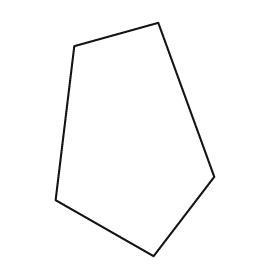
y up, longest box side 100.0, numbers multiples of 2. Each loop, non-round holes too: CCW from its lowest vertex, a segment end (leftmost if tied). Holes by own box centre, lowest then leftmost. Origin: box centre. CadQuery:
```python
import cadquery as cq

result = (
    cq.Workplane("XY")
    .moveTo(8.0, -50.0)
    .lineTo(34.0, -16.0)
    .lineTo(10.0, 50.0)
    .lineTo(-26.0, 40.0)
    .lineTo(-34.0, -26.0)
    .close()
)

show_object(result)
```